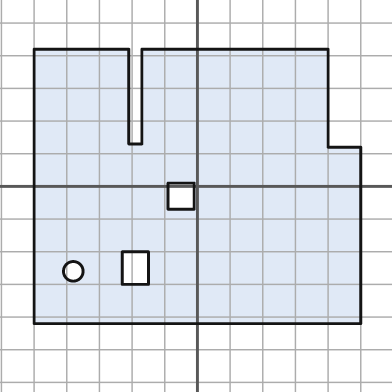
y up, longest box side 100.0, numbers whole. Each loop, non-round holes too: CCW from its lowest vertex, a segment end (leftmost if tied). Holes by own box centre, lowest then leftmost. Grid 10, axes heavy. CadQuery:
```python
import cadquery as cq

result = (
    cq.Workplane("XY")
    .moveTo(-50.0, -42.0)
    .lineTo(50.0, -42.0)
    .lineTo(50.0, 12.0)
    .lineTo(40.0, 12.0)
    .lineTo(40.0, 42.0)
    .lineTo(-17.0, 42.0)
    .lineTo(-17.0, 13.0)
    .lineTo(-21.0, 13.0)
    .lineTo(-21.0, 42.0)
    .lineTo(-50.0, 42.0)
    .close()
    .moveTo(-38.0, -26.0)
    .circle(3.0)
    .moveTo(-23.0, -30.0)
    .lineTo(-15.0, -30.0)
    .lineTo(-15.0, -20.0)
    .lineTo(-23.0, -20.0)
    .close()
    .moveTo(-9.0, -7.0)
    .lineTo(-1.0, -7.0)
    .lineTo(-1.0, 1.0)
    .lineTo(-9.0, 1.0)
    .close()
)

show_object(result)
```